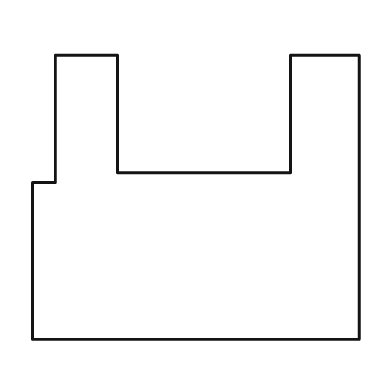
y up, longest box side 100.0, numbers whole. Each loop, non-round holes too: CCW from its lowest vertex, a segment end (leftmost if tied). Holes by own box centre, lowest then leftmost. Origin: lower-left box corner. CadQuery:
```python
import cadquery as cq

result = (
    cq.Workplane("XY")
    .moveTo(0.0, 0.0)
    .lineTo(100.0, 0.0)
    .lineTo(100.0, 87.0)
    .lineTo(79.0, 87.0)
    .lineTo(79.0, 51.0)
    .lineTo(26.0, 51.0)
    .lineTo(26.0, 87.0)
    .lineTo(7.0, 87.0)
    .lineTo(7.0, 48.0)
    .lineTo(0.0, 48.0)
    .close()
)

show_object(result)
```